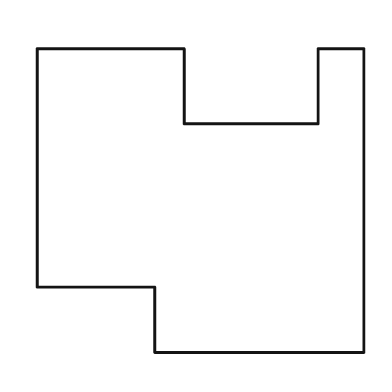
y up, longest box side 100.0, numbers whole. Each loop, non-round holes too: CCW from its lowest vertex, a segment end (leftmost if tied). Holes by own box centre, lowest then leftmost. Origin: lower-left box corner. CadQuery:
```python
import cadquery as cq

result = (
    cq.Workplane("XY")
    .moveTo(36.0, 0.0)
    .lineTo(100.0, 0.0)
    .lineTo(100.0, 93.0)
    .lineTo(86.0, 93.0)
    .lineTo(86.0, 70.0)
    .lineTo(45.0, 70.0)
    .lineTo(45.0, 93.0)
    .lineTo(0.0, 93.0)
    .lineTo(0.0, 20.0)
    .lineTo(36.0, 20.0)
    .close()
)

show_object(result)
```